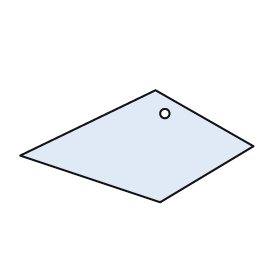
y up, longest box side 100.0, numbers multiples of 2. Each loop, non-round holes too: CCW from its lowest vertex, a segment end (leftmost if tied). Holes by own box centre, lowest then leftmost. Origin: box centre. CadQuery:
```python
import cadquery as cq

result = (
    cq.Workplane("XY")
    .moveTo(10.0, -24.0)
    .lineTo(50.0, 0.0)
    .lineTo(8.0, 24.0)
    .lineTo(-50.0, -4.0)
    .close()
    .moveTo(12.0, 14.0)
    .circle(2.0)
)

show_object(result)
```